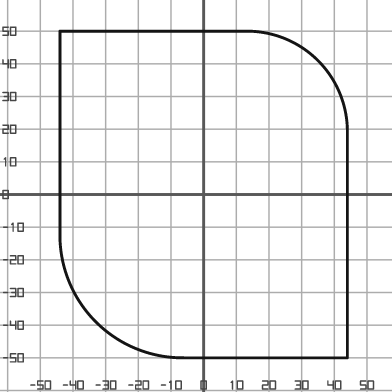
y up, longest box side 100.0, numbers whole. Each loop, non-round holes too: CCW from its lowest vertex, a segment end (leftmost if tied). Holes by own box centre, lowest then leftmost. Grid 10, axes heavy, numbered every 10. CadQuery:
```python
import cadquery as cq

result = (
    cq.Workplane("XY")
    .moveTo(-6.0, -50.0)
    .lineTo(44.0, -50.0)
    .lineTo(44.0, 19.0)
    .threePointArc((35.0, 41.0), (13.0, 50.0))
    .lineTo(-44.0, 50.0)
    .lineTo(-44.0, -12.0)
    .threePointArc((-33.0, -39.0), (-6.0, -50.0))
    .close()
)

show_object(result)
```